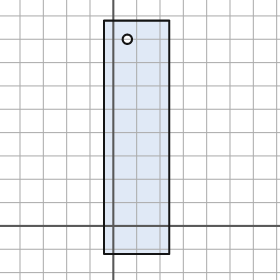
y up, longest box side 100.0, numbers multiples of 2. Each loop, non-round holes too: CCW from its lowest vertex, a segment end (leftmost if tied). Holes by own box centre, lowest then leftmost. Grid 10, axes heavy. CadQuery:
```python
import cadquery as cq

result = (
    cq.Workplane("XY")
    .moveTo(-4.0, -12.0)
    .lineTo(24.0, -12.0)
    .lineTo(24.0, 88.0)
    .lineTo(-4.0, 88.0)
    .close()
    .moveTo(6.0, 80.0)
    .circle(2.0)
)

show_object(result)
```